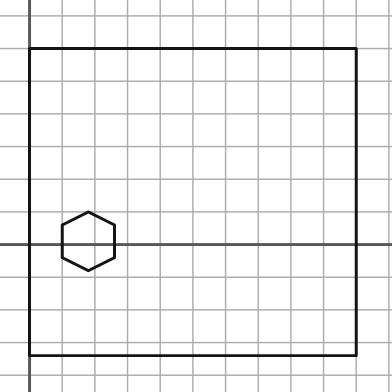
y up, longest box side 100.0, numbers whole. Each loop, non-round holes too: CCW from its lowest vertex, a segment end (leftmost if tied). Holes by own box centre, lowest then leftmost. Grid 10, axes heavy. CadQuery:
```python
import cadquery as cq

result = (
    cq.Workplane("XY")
    .moveTo(0.0, -34.0)
    .lineTo(100.0, -34.0)
    .lineTo(100.0, 60.0)
    .lineTo(0.0, 60.0)
    .close()
    .moveTo(18.0, -8.0)
    .lineTo(26.0, -4.0)
    .lineTo(26.0, 6.0)
    .lineTo(18.0, 10.0)
    .lineTo(10.0, 6.0)
    .lineTo(10.0, -4.0)
    .close()
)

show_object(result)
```